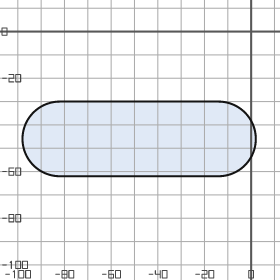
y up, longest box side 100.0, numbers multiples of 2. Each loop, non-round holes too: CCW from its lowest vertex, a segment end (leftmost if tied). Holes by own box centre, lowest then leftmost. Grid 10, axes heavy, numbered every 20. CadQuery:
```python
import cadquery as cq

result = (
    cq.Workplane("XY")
    .moveTo(-82.0, -62.0)
    .lineTo(-14.0, -62.0)
    .threePointArc((2.0, -46.0), (-14.0, -30.0))
    .lineTo(-82.0, -30.0)
    .threePointArc((-98.0, -46.0), (-82.0, -62.0))
    .close()
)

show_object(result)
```